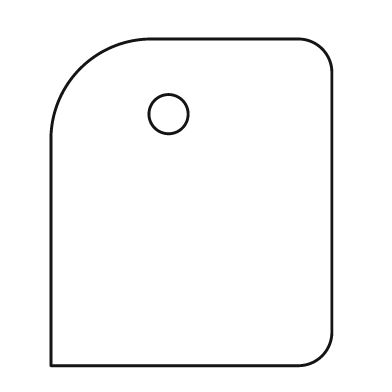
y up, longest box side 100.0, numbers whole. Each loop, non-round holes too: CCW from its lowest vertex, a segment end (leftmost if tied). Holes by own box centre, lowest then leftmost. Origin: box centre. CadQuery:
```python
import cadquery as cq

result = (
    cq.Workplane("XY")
    .moveTo(-43.0, -50.0)
    .lineTo(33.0, -50.0)
    .threePointArc((40.0, -47.0), (43.0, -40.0))
    .lineTo(43.0, 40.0)
    .threePointArc((40.0, 47.0), (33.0, 50.0))
    .lineTo(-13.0, 50.0)
    .threePointArc((-34.0, 41.0), (-43.0, 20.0))
    .close()
    .moveTo(-7.0, 27.0)
    .circle(6.0)
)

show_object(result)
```